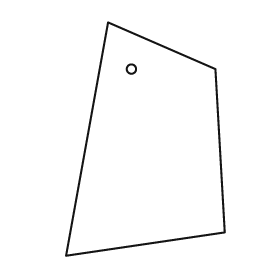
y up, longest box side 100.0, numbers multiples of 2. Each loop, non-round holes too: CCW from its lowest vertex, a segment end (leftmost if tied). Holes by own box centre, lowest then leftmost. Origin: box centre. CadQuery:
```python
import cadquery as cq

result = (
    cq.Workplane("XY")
    .moveTo(-34.0, -50.0)
    .lineTo(34.0, -40.0)
    .lineTo(30.0, 30.0)
    .lineTo(-16.0, 50.0)
    .close()
    .moveTo(-6.0, 30.0)
    .circle(2.0)
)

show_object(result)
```